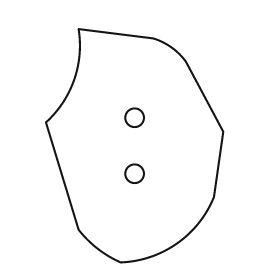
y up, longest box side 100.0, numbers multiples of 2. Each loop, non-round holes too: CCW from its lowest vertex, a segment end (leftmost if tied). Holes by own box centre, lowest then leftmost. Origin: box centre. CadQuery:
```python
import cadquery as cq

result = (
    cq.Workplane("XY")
    .moveTo(-6.0, -50.0)
    .threePointArc((18.0, -42.0), (34.0, -22.0))
    .lineTo(38.0, 6.0)
    .lineTo(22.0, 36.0)
    .threePointArc((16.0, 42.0), (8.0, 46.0))
    .lineTo(-24.0, 50.0)
    .threePointArc((-26.0, 28.0), (-38.0, 10.0))
    .lineTo(-24.0, -36.0)
    .threePointArc((-16.0, -44.0), (-6.0, -50.0))
    .close()
    .moveTo(0.0, -12.0)
    .circle(4.0)
    .moveTo(0.0, 12.0)
    .circle(4.0)
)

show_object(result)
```